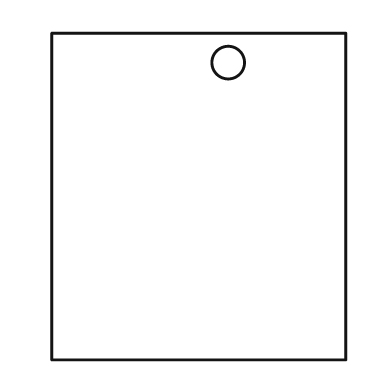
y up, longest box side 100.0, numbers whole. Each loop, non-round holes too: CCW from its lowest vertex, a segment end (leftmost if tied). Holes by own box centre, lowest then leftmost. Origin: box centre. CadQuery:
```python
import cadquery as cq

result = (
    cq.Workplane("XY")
    .moveTo(-45.0, -50.0)
    .lineTo(45.0, -50.0)
    .lineTo(45.0, 50.0)
    .lineTo(-45.0, 50.0)
    .close()
    .moveTo(9.0, 41.0)
    .circle(5.0)
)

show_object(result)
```